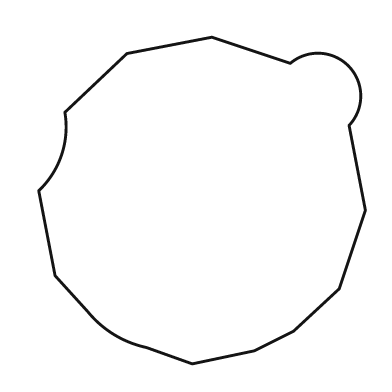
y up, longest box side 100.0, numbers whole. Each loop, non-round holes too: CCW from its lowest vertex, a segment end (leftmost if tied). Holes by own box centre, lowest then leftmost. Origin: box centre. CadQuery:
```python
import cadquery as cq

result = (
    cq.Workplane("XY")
    .moveTo(-3.0, -50.0)
    .lineTo(16.0, -46.0)
    .lineTo(28.0, -40.0)
    .lineTo(42.0, -27.0)
    .lineTo(50.0, -3.0)
    .lineTo(45.0, 23.0)
    .threePointArc((45.0, 41.0), (27.0, 42.0))
    .lineTo(3.0, 50.0)
    .lineTo(-23.0, 45.0)
    .lineTo(-42.0, 27.0)
    .threePointArc((-43.0, 14.0), (-50.0, 3.0))
    .lineTo(-45.0, -23.0)
    .lineTo(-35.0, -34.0)
    .threePointArc((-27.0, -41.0), (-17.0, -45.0))
    .close()
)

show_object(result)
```